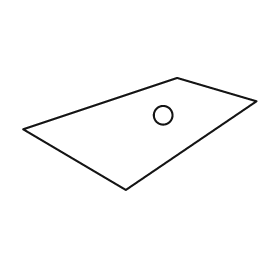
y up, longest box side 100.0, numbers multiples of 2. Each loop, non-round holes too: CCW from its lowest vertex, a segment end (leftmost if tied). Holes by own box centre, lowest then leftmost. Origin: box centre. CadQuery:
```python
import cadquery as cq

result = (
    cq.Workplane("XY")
    .moveTo(-6.0, -24.0)
    .lineTo(50.0, 14.0)
    .lineTo(16.0, 24.0)
    .lineTo(-50.0, 2.0)
    .close()
    .moveTo(10.0, 8.0)
    .circle(4.0)
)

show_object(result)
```